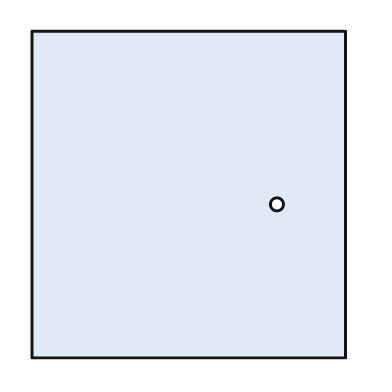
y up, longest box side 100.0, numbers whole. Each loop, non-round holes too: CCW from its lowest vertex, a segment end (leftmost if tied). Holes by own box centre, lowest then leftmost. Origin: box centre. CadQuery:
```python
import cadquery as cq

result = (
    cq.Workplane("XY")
    .moveTo(-48.0, -50.0)
    .lineTo(48.0, -50.0)
    .lineTo(48.0, 50.0)
    .lineTo(-48.0, 50.0)
    .close()
    .moveTo(27.0, -3.0)
    .circle(2.0)
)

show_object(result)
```